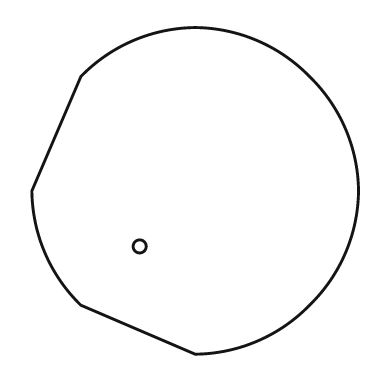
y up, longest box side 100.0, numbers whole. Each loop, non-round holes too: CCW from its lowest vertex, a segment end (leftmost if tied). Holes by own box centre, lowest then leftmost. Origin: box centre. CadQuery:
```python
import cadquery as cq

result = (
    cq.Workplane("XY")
    .moveTo(0.0, -50.0)
    .threePointArc((19.0, -46.0), (35.0, -35.0))
    .threePointArc((46.0, -19.0), (50.0, 0.0))
    .threePointArc((46.0, 19.0), (35.0, 35.0))
    .threePointArc((19.0, 46.0), (0.0, 50.0))
    .threePointArc((-19.0, 46.0), (-35.0, 35.0))
    .lineTo(-50.0, 0.0)
    .threePointArc((-46.0, -19.0), (-35.0, -35.0))
    .close()
    .moveTo(-17.0, -17.0)
    .circle(2.0)
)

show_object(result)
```